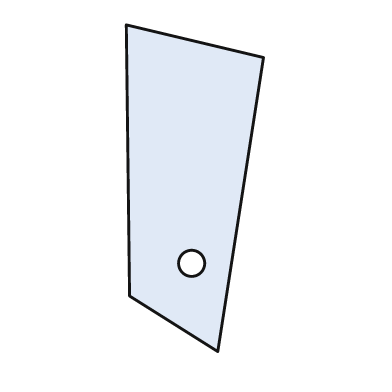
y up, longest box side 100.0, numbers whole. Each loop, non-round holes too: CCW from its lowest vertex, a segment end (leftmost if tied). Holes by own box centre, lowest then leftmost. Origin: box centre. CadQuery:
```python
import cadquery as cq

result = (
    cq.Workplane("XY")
    .moveTo(7.0, -50.0)
    .lineTo(21.0, 40.0)
    .lineTo(-21.0, 50.0)
    .lineTo(-20.0, -33.0)
    .close()
    .moveTo(-1.0, -23.0)
    .circle(4.0)
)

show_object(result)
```